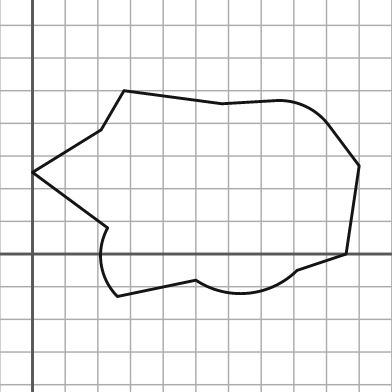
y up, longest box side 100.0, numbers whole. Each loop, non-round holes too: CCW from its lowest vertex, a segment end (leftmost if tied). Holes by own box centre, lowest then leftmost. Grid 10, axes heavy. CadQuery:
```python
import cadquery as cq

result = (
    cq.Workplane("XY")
    .moveTo(26.0, -13.0)
    .lineTo(50.0, -8.0)
    .threePointArc((66.0, -12.0), (81.0, -5.0))
    .lineTo(96.0, 0.0)
    .lineTo(100.0, 27.0)
    .lineTo(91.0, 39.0)
    .threePointArc((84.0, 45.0), (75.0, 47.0))
    .lineTo(58.0, 46.0)
    .lineTo(28.0, 50.0)
    .lineTo(21.0, 38.0)
    .lineTo(0.0, 25.0)
    .lineTo(23.0, 8.0)
    .threePointArc((21.0, -3.0), (26.0, -13.0))
    .close()
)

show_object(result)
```